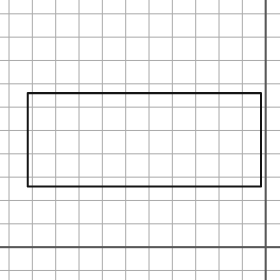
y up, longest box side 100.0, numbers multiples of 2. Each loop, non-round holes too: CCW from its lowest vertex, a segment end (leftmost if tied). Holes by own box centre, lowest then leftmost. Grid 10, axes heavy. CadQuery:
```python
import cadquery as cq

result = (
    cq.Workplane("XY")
    .moveTo(-102.0, 26.0)
    .lineTo(-2.0, 26.0)
    .lineTo(-2.0, 66.0)
    .lineTo(-102.0, 66.0)
    .close()
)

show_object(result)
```